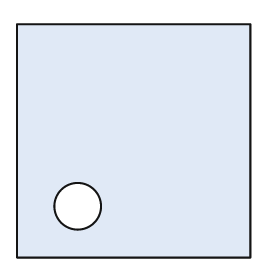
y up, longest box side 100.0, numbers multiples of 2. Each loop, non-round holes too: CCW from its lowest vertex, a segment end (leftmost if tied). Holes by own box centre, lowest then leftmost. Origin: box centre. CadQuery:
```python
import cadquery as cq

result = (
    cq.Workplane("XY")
    .moveTo(-50.0, -50.0)
    .lineTo(50.0, -50.0)
    .lineTo(50.0, 50.0)
    .lineTo(-50.0, 50.0)
    .close()
    .moveTo(-24.0, -28.0)
    .circle(10.0)
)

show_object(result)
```